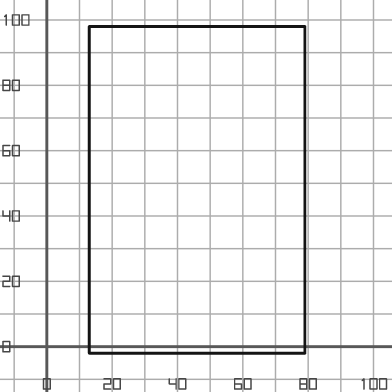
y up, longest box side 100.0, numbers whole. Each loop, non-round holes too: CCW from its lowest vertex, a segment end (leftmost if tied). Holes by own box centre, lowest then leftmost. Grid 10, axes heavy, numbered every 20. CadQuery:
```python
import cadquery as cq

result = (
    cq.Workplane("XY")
    .moveTo(13.0, -2.0)
    .lineTo(79.0, -2.0)
    .lineTo(79.0, 98.0)
    .lineTo(13.0, 98.0)
    .close()
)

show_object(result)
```